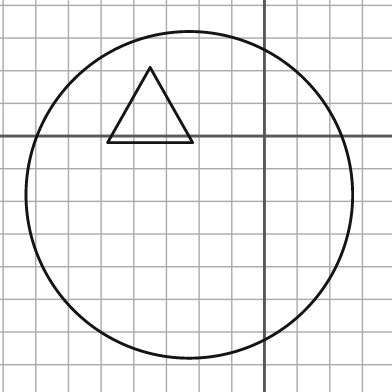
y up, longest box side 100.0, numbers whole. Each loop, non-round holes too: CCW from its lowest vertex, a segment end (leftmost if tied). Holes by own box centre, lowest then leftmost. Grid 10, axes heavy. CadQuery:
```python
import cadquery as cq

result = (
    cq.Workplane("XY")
    .moveTo(-23.0, -18.0)
    .circle(50.0)
    .moveTo(-48.0, -2.0)
    .lineTo(-22.0, -2.0)
    .lineTo(-35.0, 21.0)
    .close()
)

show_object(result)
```